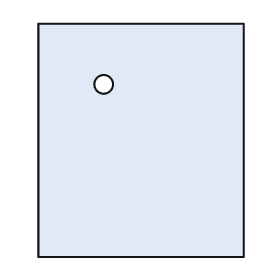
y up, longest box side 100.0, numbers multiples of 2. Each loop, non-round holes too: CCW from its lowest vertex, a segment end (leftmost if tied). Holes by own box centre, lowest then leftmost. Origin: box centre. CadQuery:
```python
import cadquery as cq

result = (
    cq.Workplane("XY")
    .moveTo(-44.0, -50.0)
    .lineTo(44.0, -50.0)
    .lineTo(44.0, 50.0)
    .lineTo(-44.0, 50.0)
    .close()
    .moveTo(-16.0, 24.0)
    .circle(4.0)
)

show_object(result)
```